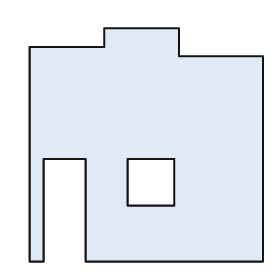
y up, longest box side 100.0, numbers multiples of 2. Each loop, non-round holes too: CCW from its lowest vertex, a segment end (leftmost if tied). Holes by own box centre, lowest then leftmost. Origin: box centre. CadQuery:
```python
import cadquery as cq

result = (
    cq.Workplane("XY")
    .moveTo(-50.0, -50.0)
    .lineTo(-44.0, -50.0)
    .lineTo(-44.0, -6.0)
    .lineTo(-26.0, -6.0)
    .lineTo(-26.0, -50.0)
    .lineTo(50.0, -50.0)
    .lineTo(50.0, 38.0)
    .lineTo(14.0, 38.0)
    .lineTo(14.0, 50.0)
    .lineTo(-18.0, 50.0)
    .lineTo(-18.0, 42.0)
    .lineTo(-50.0, 42.0)
    .close()
    .moveTo(-8.0, -26.0)
    .lineTo(12.0, -26.0)
    .lineTo(12.0, -6.0)
    .lineTo(-8.0, -6.0)
    .close()
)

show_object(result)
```